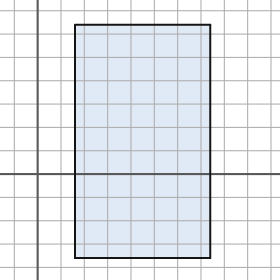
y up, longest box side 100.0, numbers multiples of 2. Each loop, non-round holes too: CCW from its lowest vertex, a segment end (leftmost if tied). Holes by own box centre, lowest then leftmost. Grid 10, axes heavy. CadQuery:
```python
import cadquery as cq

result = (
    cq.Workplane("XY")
    .moveTo(16.0, -36.0)
    .lineTo(74.0, -36.0)
    .lineTo(74.0, 64.0)
    .lineTo(16.0, 64.0)
    .close()
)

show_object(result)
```